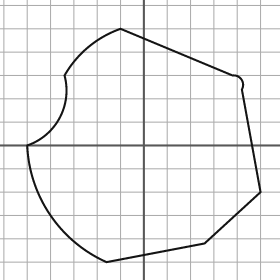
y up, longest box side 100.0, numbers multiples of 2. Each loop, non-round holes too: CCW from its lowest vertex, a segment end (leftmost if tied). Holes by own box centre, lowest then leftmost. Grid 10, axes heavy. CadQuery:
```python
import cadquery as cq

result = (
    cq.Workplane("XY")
    .moveTo(-16.0, -50.0)
    .lineTo(26.0, -42.0)
    .lineTo(50.0, -20.0)
    .lineTo(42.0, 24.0)
    .threePointArc((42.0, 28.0), (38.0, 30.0))
    .lineTo(-10.0, 50.0)
    .threePointArc((-24.0, 42.0), (-34.0, 30.0))
    .threePointArc((-36.0, 12.0), (-50.0, 0.0))
    .threePointArc((-40.0, -30.0), (-16.0, -50.0))
    .close()
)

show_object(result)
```